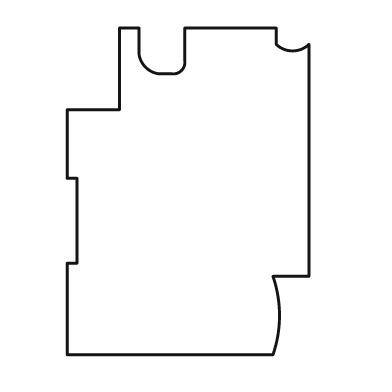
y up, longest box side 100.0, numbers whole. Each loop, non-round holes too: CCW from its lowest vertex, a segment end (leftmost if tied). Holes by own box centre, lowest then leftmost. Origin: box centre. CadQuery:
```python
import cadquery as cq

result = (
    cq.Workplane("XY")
    .moveTo(-37.0, -50.0)
    .lineTo(26.0, -50.0)
    .threePointArc((28.0, -38.0), (26.0, -26.0))
    .lineTo(37.0, -26.0)
    .lineTo(37.0, 45.0)
    .threePointArc((32.0, 43.0), (27.0, 45.0))
    .lineTo(27.0, 50.0)
    .lineTo(-1.0, 50.0)
    .lineTo(-1.0, 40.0)
    .threePointArc((-2.0, 37.0), (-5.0, 36.0))
    .lineTo(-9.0, 36.0)
    .threePointArc((-13.0, 38.0), (-15.0, 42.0))
    .lineTo(-15.0, 50.0)
    .lineTo(-21.0, 50.0)
    .lineTo(-21.0, 25.0)
    .lineTo(-37.0, 25.0)
    .lineTo(-37.0, 4.0)
    .lineTo(-34.0, 4.0)
    .lineTo(-34.0, -22.0)
    .lineTo(-37.0, -22.0)
    .close()
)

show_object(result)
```